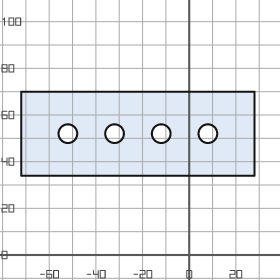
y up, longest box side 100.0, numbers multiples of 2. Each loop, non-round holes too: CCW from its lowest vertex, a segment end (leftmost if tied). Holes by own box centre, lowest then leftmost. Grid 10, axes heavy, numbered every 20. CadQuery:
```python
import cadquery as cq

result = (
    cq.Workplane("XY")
    .moveTo(-72.0, 34.0)
    .lineTo(28.0, 34.0)
    .lineTo(28.0, 70.0)
    .lineTo(-72.0, 70.0)
    .close()
    .moveTo(-52.0, 52.0)
    .circle(4.0)
    .moveTo(-32.0, 52.0)
    .circle(4.0)
    .moveTo(-12.0, 52.0)
    .circle(4.0)
    .moveTo(8.0, 52.0)
    .circle(4.0)
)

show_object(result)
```